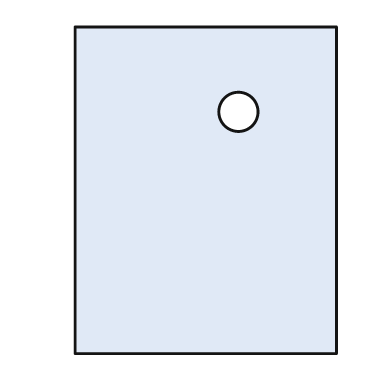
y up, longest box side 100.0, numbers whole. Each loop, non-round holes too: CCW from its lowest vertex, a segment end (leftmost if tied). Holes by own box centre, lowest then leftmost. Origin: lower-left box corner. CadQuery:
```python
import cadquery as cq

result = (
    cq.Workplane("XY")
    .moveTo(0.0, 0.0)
    .lineTo(80.0, 0.0)
    .lineTo(80.0, 100.0)
    .lineTo(0.0, 100.0)
    .close()
    .moveTo(50.0, 74.0)
    .circle(6.0)
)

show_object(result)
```